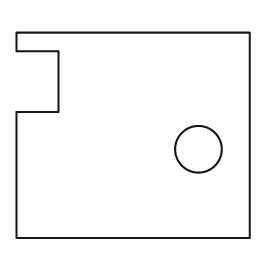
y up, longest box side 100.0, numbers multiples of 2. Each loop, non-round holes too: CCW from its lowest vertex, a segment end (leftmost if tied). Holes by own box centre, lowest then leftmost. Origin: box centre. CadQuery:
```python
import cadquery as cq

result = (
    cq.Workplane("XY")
    .moveTo(-50.0, -44.0)
    .lineTo(50.0, -44.0)
    .lineTo(50.0, 44.0)
    .lineTo(-50.0, 44.0)
    .lineTo(-50.0, 36.0)
    .lineTo(-32.0, 36.0)
    .lineTo(-32.0, 10.0)
    .lineTo(-50.0, 10.0)
    .close()
    .moveTo(28.0, -6.0)
    .circle(10.0)
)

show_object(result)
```